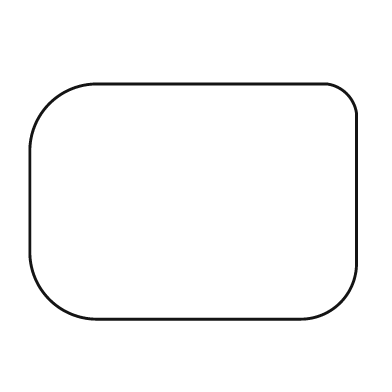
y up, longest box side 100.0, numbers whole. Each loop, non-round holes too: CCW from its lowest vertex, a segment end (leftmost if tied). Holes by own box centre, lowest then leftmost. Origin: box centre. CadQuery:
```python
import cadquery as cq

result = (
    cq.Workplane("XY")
    .moveTo(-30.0, -36.0)
    .lineTo(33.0, -36.0)
    .threePointArc((45.0, -31.0), (50.0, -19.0))
    .lineTo(50.0, 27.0)
    .threePointArc((47.0, 33.0), (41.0, 36.0))
    .lineTo(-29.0, 36.0)
    .threePointArc((-44.0, 30.0), (-50.0, 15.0))
    .lineTo(-50.0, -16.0)
    .threePointArc((-44.0, -30.0), (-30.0, -36.0))
    .close()
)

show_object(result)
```